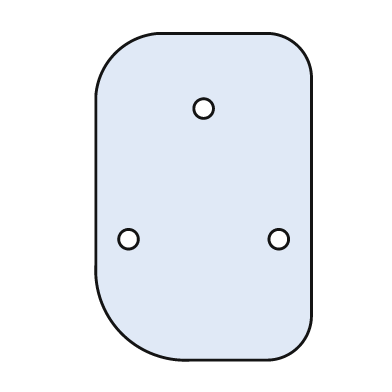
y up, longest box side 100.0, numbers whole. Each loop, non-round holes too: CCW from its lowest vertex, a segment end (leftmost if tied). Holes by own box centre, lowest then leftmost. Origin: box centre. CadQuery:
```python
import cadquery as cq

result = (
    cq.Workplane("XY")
    .moveTo(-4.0, -50.0)
    .lineTo(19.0, -50.0)
    .threePointArc((29.0, -46.0), (33.0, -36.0))
    .lineTo(33.0, 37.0)
    .threePointArc((29.0, 46.0), (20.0, 50.0))
    .lineTo(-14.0, 50.0)
    .threePointArc((-27.0, 44.0), (-33.0, 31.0))
    .lineTo(-33.0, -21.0)
    .threePointArc((-25.0, -42.0), (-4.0, -50.0))
    .close()
    .moveTo(-23.0, -13.0)
    .circle(3.0)
    .moveTo(23.0, -13.0)
    .circle(3.0)
    .moveTo(0.0, 27.0)
    .circle(3.0)
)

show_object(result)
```